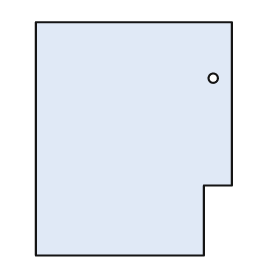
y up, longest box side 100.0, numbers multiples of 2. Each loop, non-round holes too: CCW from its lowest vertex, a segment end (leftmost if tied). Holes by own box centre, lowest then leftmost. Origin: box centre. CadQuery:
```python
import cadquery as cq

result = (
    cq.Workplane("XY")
    .moveTo(-42.0, -50.0)
    .lineTo(30.0, -50.0)
    .lineTo(30.0, -20.0)
    .lineTo(42.0, -20.0)
    .lineTo(42.0, 50.0)
    .lineTo(-42.0, 50.0)
    .close()
    .moveTo(34.0, 26.0)
    .circle(2.0)
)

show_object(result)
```